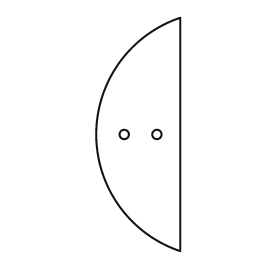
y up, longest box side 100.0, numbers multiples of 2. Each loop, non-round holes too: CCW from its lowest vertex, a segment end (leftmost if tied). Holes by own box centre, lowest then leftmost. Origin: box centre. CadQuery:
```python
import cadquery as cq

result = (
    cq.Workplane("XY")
    .moveTo(18.0, -50.0)
    .lineTo(18.0, 50.0)
    .threePointArc((-18.0, 0.0), (18.0, -50.0))
    .close()
    .moveTo(-6.0, 0.0)
    .circle(2.0)
    .moveTo(8.0, 0.0)
    .circle(2.0)
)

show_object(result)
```